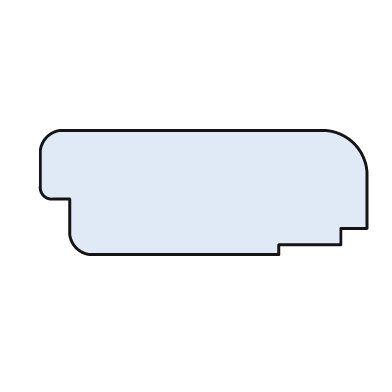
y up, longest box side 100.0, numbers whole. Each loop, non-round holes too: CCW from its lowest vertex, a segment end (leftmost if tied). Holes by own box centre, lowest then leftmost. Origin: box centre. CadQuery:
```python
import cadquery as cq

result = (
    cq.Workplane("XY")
    .moveTo(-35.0, -19.0)
    .lineTo(23.0, -19.0)
    .lineTo(23.0, -16.0)
    .lineTo(42.0, -16.0)
    .lineTo(42.0, -11.0)
    .lineTo(50.0, -11.0)
    .lineTo(50.0, 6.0)
    .threePointArc((46.0, 15.0), (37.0, 19.0))
    .lineTo(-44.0, 19.0)
    .threePointArc((-48.0, 17.0), (-50.0, 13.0))
    .lineTo(-50.0, 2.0)
    .threePointArc((-49.0, -1.0), (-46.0, -2.0))
    .lineTo(-41.0, -2.0)
    .lineTo(-41.0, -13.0)
    .threePointArc((-39.0, -17.0), (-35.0, -19.0))
    .close()
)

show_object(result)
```